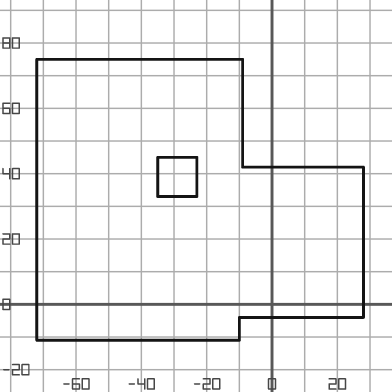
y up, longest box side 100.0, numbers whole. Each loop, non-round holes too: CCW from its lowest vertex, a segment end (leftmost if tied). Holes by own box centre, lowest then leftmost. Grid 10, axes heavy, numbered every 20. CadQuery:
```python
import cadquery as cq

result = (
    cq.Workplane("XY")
    .moveTo(-72.0, -11.0)
    .lineTo(-10.0, -11.0)
    .lineTo(-10.0, -4.0)
    .lineTo(28.0, -4.0)
    .lineTo(28.0, 42.0)
    .lineTo(-9.0, 42.0)
    .lineTo(-9.0, 75.0)
    .lineTo(-72.0, 75.0)
    .close()
    .moveTo(-35.0, 33.0)
    .lineTo(-23.0, 33.0)
    .lineTo(-23.0, 45.0)
    .lineTo(-35.0, 45.0)
    .close()
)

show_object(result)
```